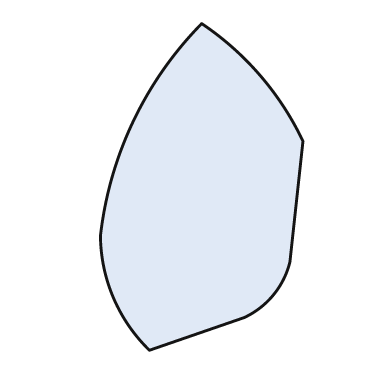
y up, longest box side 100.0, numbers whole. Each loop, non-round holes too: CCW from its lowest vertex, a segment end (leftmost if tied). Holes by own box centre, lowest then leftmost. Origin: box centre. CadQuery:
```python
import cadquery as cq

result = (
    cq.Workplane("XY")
    .moveTo(-16.0, -50.0)
    .lineTo(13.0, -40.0)
    .threePointArc((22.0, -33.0), (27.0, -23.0))
    .lineTo(31.0, 14.0)
    .threePointArc((18.0, 34.0), (0.0, 50.0))
    .threePointArc((-21.0, 20.0), (-31.0, -15.0))
    .threePointArc((-27.0, -34.0), (-16.0, -50.0))
    .close()
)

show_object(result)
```